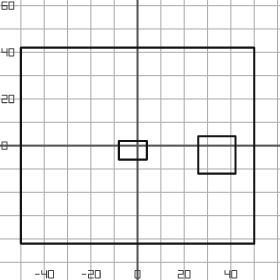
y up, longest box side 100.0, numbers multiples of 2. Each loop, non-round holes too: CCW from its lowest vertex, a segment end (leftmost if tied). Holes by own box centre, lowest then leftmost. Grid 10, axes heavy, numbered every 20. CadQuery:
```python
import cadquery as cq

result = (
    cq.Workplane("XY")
    .moveTo(-50.0, -42.0)
    .lineTo(50.0, -42.0)
    .lineTo(50.0, 42.0)
    .lineTo(-50.0, 42.0)
    .close()
    .moveTo(26.0, -12.0)
    .lineTo(42.0, -12.0)
    .lineTo(42.0, 4.0)
    .lineTo(26.0, 4.0)
    .close()
    .moveTo(-8.0, -6.0)
    .lineTo(4.0, -6.0)
    .lineTo(4.0, 2.0)
    .lineTo(-8.0, 2.0)
    .close()
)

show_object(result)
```